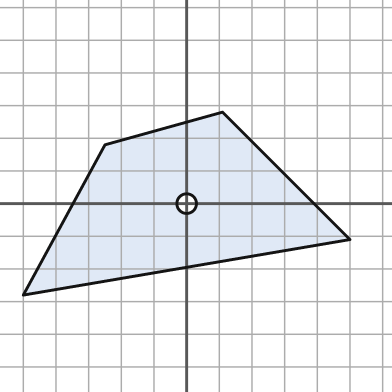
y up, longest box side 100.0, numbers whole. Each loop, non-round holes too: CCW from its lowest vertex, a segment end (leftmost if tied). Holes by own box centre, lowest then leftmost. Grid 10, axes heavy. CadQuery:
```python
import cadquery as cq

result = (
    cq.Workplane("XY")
    .moveTo(-50.0, -28.0)
    .lineTo(50.0, -11.0)
    .lineTo(11.0, 28.0)
    .lineTo(-25.0, 18.0)
    .close()
    .moveTo(0.0, 0.0)
    .circle(3.0)
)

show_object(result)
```